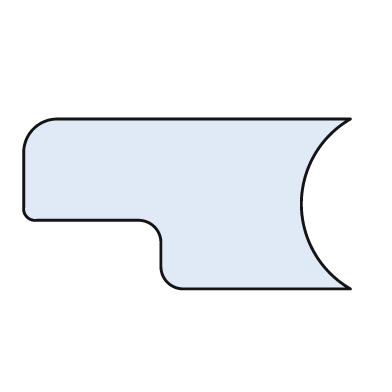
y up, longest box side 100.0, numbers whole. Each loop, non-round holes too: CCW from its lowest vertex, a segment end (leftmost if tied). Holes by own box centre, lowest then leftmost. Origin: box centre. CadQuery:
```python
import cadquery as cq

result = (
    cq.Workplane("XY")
    .moveTo(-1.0, -26.0)
    .lineTo(50.0, -26.0)
    .threePointArc((35.0, 0.0), (50.0, 26.0))
    .lineTo(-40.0, 26.0)
    .threePointArc((-47.0, 23.0), (-50.0, 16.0))
    .lineTo(-50.0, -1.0)
    .threePointArc((-49.0, -4.0), (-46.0, -5.0))
    .lineTo(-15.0, -5.0)
    .threePointArc((-10.0, -7.0), (-8.0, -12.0))
    .lineTo(-8.0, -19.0)
    .threePointArc((-6.0, -24.0), (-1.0, -26.0))
    .close()
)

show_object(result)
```